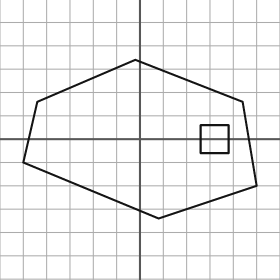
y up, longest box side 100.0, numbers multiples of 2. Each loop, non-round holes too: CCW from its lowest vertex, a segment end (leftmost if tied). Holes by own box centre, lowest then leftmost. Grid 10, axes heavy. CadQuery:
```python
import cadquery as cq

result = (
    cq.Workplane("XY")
    .moveTo(8.0, -34.0)
    .lineTo(50.0, -20.0)
    .lineTo(44.0, 16.0)
    .lineTo(-2.0, 34.0)
    .lineTo(-44.0, 16.0)
    .lineTo(-50.0, -10.0)
    .close()
    .moveTo(26.0, -6.0)
    .lineTo(38.0, -6.0)
    .lineTo(38.0, 6.0)
    .lineTo(26.0, 6.0)
    .close()
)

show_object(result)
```